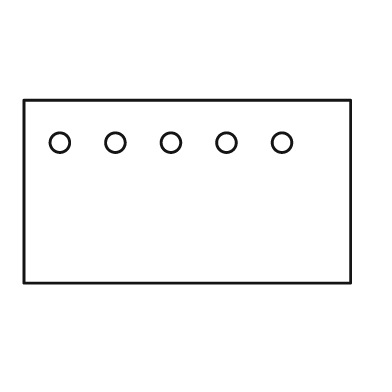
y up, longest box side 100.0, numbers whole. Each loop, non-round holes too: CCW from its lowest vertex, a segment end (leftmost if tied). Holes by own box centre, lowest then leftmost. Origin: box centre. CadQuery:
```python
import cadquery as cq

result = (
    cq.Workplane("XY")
    .moveTo(-50.0, -28.0)
    .lineTo(50.0, -28.0)
    .lineTo(50.0, 28.0)
    .lineTo(-50.0, 28.0)
    .close()
    .moveTo(-39.0, 15.0)
    .circle(3.0)
    .moveTo(-22.0, 15.0)
    .circle(3.0)
    .moveTo(-5.0, 15.0)
    .circle(3.0)
    .moveTo(12.0, 15.0)
    .circle(3.0)
    .moveTo(29.0, 15.0)
    .circle(3.0)
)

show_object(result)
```